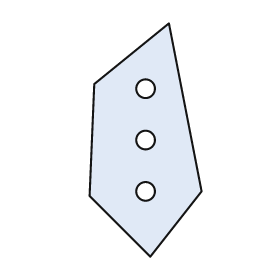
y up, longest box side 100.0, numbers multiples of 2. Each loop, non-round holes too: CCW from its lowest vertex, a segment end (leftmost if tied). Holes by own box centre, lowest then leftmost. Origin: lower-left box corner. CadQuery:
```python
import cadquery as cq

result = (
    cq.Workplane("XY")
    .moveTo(26.0, 0.0)
    .lineTo(48.0, 28.0)
    .lineTo(34.0, 100.0)
    .lineTo(2.0, 74.0)
    .lineTo(0.0, 26.0)
    .close()
    .moveTo(24.0, 28.0)
    .circle(4.0)
    .moveTo(24.0, 50.0)
    .circle(4.0)
    .moveTo(24.0, 72.0)
    .circle(4.0)
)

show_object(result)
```